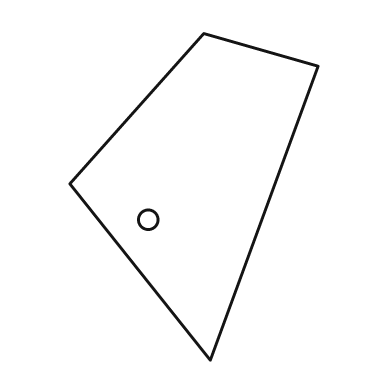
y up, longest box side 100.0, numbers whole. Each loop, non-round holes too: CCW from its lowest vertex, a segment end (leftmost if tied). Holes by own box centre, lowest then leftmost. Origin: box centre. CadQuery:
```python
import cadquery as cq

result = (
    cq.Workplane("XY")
    .moveTo(5.0, -50.0)
    .lineTo(38.0, 40.0)
    .lineTo(3.0, 50.0)
    .lineTo(-38.0, 4.0)
    .close()
    .moveTo(-14.0, -7.0)
    .circle(3.0)
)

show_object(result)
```